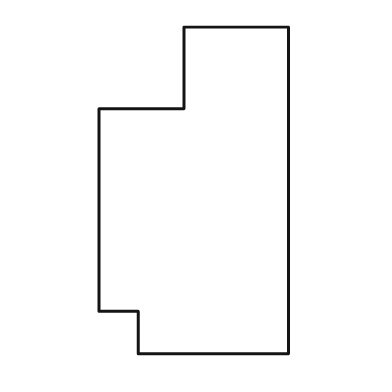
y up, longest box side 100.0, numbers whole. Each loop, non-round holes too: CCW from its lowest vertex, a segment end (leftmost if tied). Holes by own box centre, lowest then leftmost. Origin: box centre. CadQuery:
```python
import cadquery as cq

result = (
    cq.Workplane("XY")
    .moveTo(-17.0, -50.0)
    .lineTo(29.0, -50.0)
    .lineTo(29.0, 50.0)
    .lineTo(-3.0, 50.0)
    .lineTo(-3.0, 25.0)
    .lineTo(-29.0, 25.0)
    .lineTo(-29.0, -37.0)
    .lineTo(-17.0, -37.0)
    .close()
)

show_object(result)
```